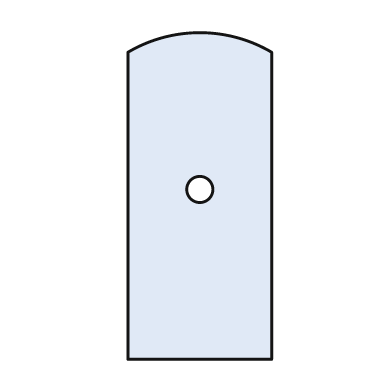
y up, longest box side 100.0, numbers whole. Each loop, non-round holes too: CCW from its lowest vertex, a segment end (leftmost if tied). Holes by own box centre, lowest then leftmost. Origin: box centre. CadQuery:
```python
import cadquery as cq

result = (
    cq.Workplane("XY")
    .moveTo(-22.0, -50.0)
    .lineTo(22.0, -50.0)
    .lineTo(22.0, 44.0)
    .threePointArc((0.0, 50.0), (-22.0, 44.0))
    .close()
    .moveTo(0.0, 2.0)
    .circle(4.0)
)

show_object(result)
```